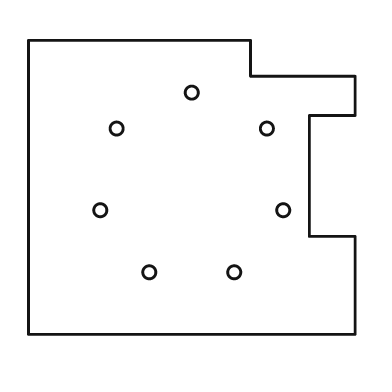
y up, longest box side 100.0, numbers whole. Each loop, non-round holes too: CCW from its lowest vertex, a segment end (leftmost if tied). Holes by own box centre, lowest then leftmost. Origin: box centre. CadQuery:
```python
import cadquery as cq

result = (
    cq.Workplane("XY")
    .moveTo(-50.0, -45.0)
    .lineTo(50.0, -45.0)
    .lineTo(50.0, -15.0)
    .lineTo(36.0, -15.0)
    .lineTo(36.0, 22.0)
    .lineTo(50.0, 22.0)
    .lineTo(50.0, 34.0)
    .lineTo(18.0, 34.0)
    .lineTo(18.0, 45.0)
    .lineTo(-50.0, 45.0)
    .close()
    .moveTo(-13.0, -26.0)
    .circle(2.0)
    .moveTo(13.0, -26.0)
    .circle(2.0)
    .moveTo(-28.0, -7.0)
    .circle(2.0)
    .moveTo(28.0, -7.0)
    .circle(2.0)
    .moveTo(-23.0, 18.0)
    .circle(2.0)
    .moveTo(23.0, 18.0)
    .circle(2.0)
    .moveTo(0.0, 29.0)
    .circle(2.0)
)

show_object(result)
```